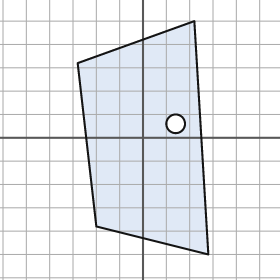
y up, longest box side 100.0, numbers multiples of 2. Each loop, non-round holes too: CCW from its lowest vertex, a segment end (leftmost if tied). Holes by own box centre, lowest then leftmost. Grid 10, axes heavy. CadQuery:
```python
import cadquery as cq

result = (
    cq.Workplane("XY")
    .moveTo(28.0, -50.0)
    .lineTo(22.0, 50.0)
    .lineTo(-28.0, 32.0)
    .lineTo(-20.0, -38.0)
    .close()
    .moveTo(14.0, 6.0)
    .circle(4.0)
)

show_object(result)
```